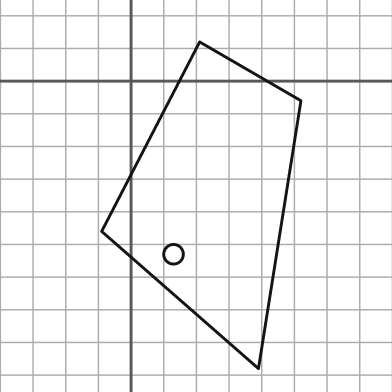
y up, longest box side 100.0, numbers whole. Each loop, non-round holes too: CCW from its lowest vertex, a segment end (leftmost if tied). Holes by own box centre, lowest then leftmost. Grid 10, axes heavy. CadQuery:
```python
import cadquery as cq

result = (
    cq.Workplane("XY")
    .moveTo(39.0, -88.0)
    .lineTo(52.0, -6.0)
    .lineTo(21.0, 12.0)
    .lineTo(-9.0, -46.0)
    .close()
    .moveTo(13.0, -53.0)
    .circle(3.0)
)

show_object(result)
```